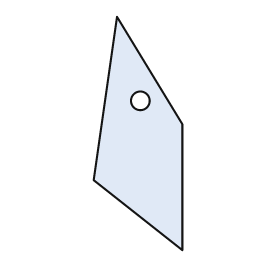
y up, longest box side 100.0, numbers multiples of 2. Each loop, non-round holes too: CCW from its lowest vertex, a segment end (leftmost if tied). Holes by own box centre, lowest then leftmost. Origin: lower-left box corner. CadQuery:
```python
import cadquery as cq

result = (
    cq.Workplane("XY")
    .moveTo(38.0, 0.0)
    .lineTo(38.0, 54.0)
    .lineTo(10.0, 100.0)
    .lineTo(0.0, 30.0)
    .close()
    .moveTo(20.0, 64.0)
    .circle(4.0)
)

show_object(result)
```